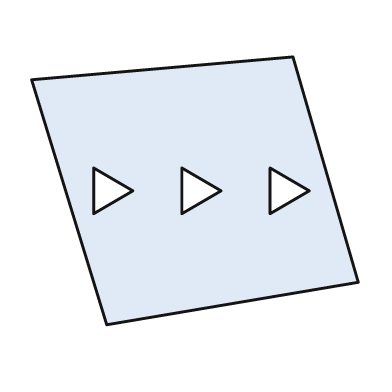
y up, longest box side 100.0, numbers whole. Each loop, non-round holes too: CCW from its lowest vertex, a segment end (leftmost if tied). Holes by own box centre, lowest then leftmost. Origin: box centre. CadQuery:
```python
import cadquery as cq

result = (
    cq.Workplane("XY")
    .moveTo(-27.0, -41.0)
    .lineTo(50.0, -28.0)
    .lineTo(30.0, 41.0)
    .lineTo(-50.0, 34.0)
    .close()
    .moveTo(-31.0, -7.0)
    .lineTo(-19.0, 0.0)
    .lineTo(-31.0, 7.0)
    .close()
    .moveTo(-4.0, -7.0)
    .lineTo(8.0, 0.0)
    .lineTo(-4.0, 7.0)
    .close()
    .moveTo(23.0, -7.0)
    .lineTo(35.0, 0.0)
    .lineTo(23.0, 7.0)
    .close()
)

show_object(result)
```